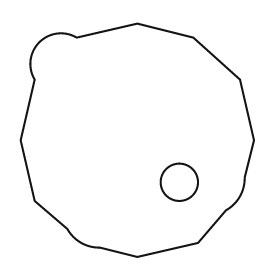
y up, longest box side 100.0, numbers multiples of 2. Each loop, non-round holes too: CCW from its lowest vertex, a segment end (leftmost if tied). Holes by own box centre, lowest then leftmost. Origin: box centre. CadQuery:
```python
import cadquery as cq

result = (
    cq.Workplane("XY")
    .moveTo(0.0, -50.0)
    .lineTo(26.0, -44.0)
    .lineTo(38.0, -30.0)
    .threePointArc((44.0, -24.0), (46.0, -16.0))
    .lineTo(50.0, 0.0)
    .lineTo(44.0, 26.0)
    .lineTo(24.0, 44.0)
    .lineTo(0.0, 50.0)
    .lineTo(-26.0, 44.0)
    .threePointArc((-42.0, 42.0), (-44.0, 26.0))
    .lineTo(-50.0, 0.0)
    .lineTo(-44.0, -26.0)
    .lineTo(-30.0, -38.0)
    .threePointArc((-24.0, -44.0), (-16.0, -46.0))
    .close()
    .moveTo(18.0, -18.0)
    .circle(8.0)
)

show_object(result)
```